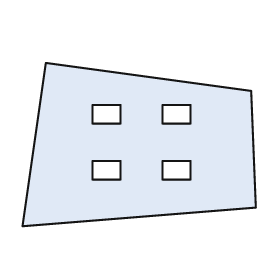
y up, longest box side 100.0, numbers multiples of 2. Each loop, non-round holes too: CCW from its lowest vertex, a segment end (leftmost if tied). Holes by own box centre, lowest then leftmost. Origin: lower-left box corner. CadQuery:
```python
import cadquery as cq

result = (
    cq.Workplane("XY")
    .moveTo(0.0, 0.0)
    .lineTo(100.0, 8.0)
    .lineTo(98.0, 58.0)
    .lineTo(10.0, 70.0)
    .close()
    .moveTo(30.0, 20.0)
    .lineTo(42.0, 20.0)
    .lineTo(42.0, 28.0)
    .lineTo(30.0, 28.0)
    .close()
    .moveTo(60.0, 20.0)
    .lineTo(72.0, 20.0)
    .lineTo(72.0, 28.0)
    .lineTo(60.0, 28.0)
    .close()
    .moveTo(30.0, 44.0)
    .lineTo(42.0, 44.0)
    .lineTo(42.0, 52.0)
    .lineTo(30.0, 52.0)
    .close()
    .moveTo(60.0, 44.0)
    .lineTo(72.0, 44.0)
    .lineTo(72.0, 52.0)
    .lineTo(60.0, 52.0)
    .close()
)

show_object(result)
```